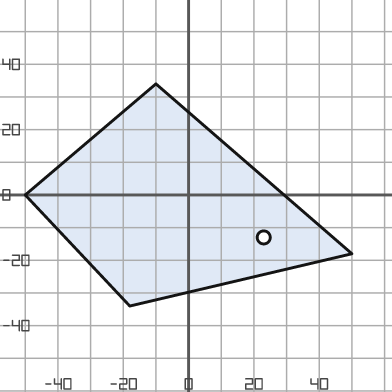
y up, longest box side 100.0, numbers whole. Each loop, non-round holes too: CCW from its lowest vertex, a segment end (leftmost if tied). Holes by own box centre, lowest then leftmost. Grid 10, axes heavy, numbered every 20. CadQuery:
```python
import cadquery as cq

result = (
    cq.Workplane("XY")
    .moveTo(-18.0, -34.0)
    .lineTo(50.0, -18.0)
    .lineTo(-10.0, 34.0)
    .lineTo(-50.0, 0.0)
    .close()
    .moveTo(23.0, -13.0)
    .circle(2.0)
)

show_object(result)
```